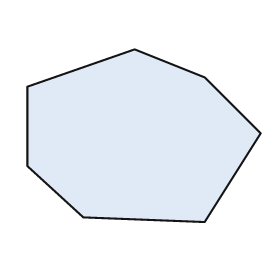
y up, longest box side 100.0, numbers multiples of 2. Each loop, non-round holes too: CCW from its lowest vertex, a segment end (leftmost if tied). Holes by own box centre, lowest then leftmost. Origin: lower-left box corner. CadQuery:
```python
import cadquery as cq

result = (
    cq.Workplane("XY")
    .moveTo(76.0, 0.0)
    .lineTo(100.0, 38.0)
    .lineTo(76.0, 62.0)
    .lineTo(46.0, 74.0)
    .lineTo(0.0, 58.0)
    .lineTo(0.0, 24.0)
    .lineTo(24.0, 2.0)
    .close()
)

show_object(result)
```